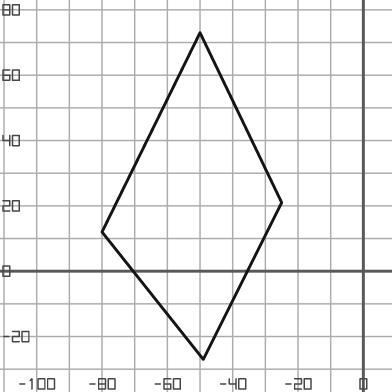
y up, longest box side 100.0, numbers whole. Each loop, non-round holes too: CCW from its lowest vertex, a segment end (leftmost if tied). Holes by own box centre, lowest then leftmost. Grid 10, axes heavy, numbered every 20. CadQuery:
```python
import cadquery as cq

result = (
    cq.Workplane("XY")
    .moveTo(-49.0, -27.0)
    .lineTo(-25.0, 21.0)
    .lineTo(-50.0, 73.0)
    .lineTo(-80.0, 12.0)
    .close()
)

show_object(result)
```